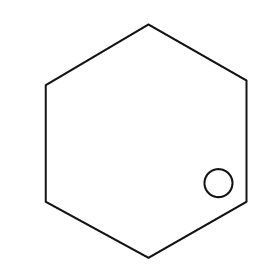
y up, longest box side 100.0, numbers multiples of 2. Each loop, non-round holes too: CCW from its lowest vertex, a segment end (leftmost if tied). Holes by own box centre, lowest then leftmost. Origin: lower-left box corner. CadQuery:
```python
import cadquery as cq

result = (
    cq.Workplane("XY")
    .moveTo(44.0, 0.0)
    .lineTo(86.0, 24.0)
    .lineTo(86.0, 76.0)
    .lineTo(44.0, 100.0)
    .lineTo(0.0, 74.0)
    .lineTo(0.0, 24.0)
    .close()
    .moveTo(74.0, 32.0)
    .circle(6.0)
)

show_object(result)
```